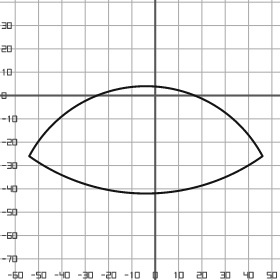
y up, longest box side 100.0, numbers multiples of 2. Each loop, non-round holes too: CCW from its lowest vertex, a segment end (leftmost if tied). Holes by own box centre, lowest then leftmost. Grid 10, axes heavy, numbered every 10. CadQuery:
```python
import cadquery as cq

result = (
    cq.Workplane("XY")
    .moveTo(-54.0, -26.0)
    .threePointArc((-4.0, -42.0), (46.0, -26.0))
    .threePointArc((-4.0, 4.0), (-54.0, -26.0))
    .close()
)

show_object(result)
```